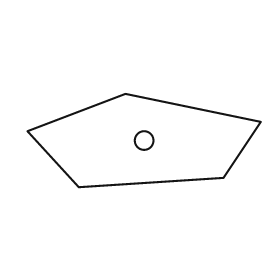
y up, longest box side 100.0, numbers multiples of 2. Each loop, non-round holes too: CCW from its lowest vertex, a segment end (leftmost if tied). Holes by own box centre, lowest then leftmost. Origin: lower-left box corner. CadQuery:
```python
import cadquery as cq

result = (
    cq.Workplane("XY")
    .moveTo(22.0, 0.0)
    .lineTo(84.0, 4.0)
    .lineTo(100.0, 28.0)
    .lineTo(42.0, 40.0)
    .lineTo(0.0, 24.0)
    .close()
    .moveTo(50.0, 20.0)
    .circle(4.0)
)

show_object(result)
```